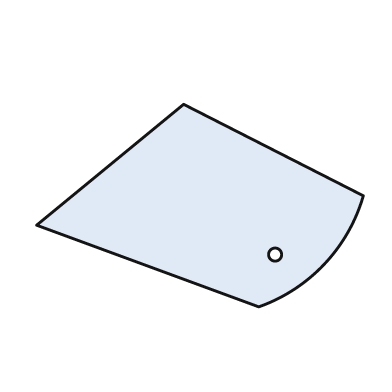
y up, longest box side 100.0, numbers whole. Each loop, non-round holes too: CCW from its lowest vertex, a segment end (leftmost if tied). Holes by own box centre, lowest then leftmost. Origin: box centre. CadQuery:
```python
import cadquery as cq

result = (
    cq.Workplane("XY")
    .moveTo(18.0, -31.0)
    .threePointArc((38.0, -18.0), (50.0, 3.0))
    .lineTo(-5.0, 31.0)
    .lineTo(-50.0, -6.0)
    .close()
    .moveTo(23.0, -15.0)
    .circle(2.0)
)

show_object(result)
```